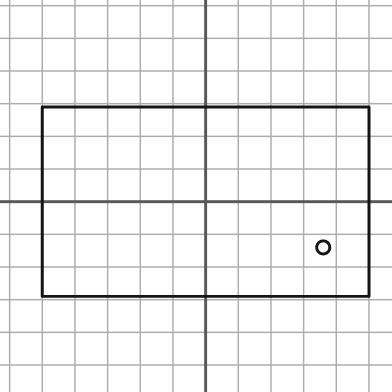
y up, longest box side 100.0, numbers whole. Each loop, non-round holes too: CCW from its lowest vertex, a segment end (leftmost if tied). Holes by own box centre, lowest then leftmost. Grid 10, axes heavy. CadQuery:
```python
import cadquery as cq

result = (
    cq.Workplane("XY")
    .moveTo(-50.0, -29.0)
    .lineTo(50.0, -29.0)
    .lineTo(50.0, 29.0)
    .lineTo(-50.0, 29.0)
    .close()
    .moveTo(36.0, -14.0)
    .circle(2.0)
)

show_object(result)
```